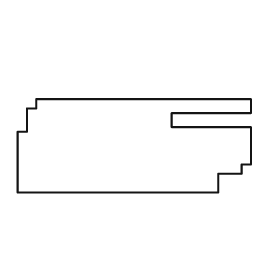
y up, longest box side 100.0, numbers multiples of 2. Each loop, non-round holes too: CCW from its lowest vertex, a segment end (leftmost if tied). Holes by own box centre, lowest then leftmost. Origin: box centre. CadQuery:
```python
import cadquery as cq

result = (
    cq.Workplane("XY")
    .moveTo(-50.0, -20.0)
    .lineTo(36.0, -20.0)
    .lineTo(36.0, -12.0)
    .lineTo(46.0, -12.0)
    .lineTo(46.0, -8.0)
    .lineTo(50.0, -8.0)
    .lineTo(50.0, 8.0)
    .lineTo(16.0, 8.0)
    .lineTo(16.0, 14.0)
    .lineTo(50.0, 14.0)
    .lineTo(50.0, 20.0)
    .lineTo(-42.0, 20.0)
    .lineTo(-42.0, 16.0)
    .lineTo(-46.0, 16.0)
    .lineTo(-46.0, 6.0)
    .lineTo(-50.0, 6.0)
    .close()
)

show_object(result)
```